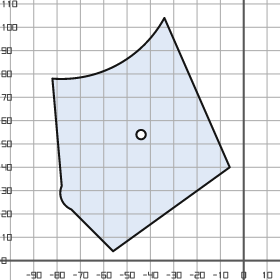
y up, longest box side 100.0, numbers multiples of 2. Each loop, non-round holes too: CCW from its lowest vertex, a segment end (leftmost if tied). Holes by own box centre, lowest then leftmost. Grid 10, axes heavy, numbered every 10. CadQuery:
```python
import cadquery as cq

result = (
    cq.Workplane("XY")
    .moveTo(-56.0, 4.0)
    .lineTo(-6.0, 40.0)
    .lineTo(-34.0, 104.0)
    .threePointArc((-54.0, 84.0), (-82.0, 78.0))
    .lineTo(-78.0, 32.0)
    .threePointArc((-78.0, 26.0), (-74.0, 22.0))
    .close()
    .moveTo(-44.0, 54.0)
    .circle(2.0)
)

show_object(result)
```